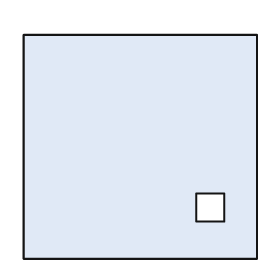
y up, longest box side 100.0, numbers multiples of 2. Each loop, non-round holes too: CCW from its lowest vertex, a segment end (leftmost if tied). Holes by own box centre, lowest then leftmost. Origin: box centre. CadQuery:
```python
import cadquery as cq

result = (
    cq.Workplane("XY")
    .moveTo(-50.0, -48.0)
    .lineTo(50.0, -48.0)
    .lineTo(50.0, 48.0)
    .lineTo(-50.0, 48.0)
    .close()
    .moveTo(24.0, -32.0)
    .lineTo(36.0, -32.0)
    .lineTo(36.0, -20.0)
    .lineTo(24.0, -20.0)
    .close()
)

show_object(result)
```